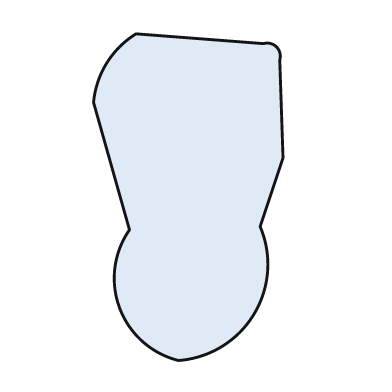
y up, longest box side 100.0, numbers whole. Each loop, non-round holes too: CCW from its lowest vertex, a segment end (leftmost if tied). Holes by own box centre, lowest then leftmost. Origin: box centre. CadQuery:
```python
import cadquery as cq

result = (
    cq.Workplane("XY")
    .moveTo(-3.0, -50.0)
    .threePointArc((20.0, -36.0), (22.0, -9.0))
    .lineTo(29.0, 12.0)
    .lineTo(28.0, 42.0)
    .threePointArc((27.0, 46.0), (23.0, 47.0))
    .lineTo(-16.0, 50.0)
    .threePointArc((-25.0, 41.0), (-29.0, 29.0))
    .lineTo(-18.0, -10.0)
    .threePointArc((-21.0, -34.0), (-3.0, -50.0))
    .close()
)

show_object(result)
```